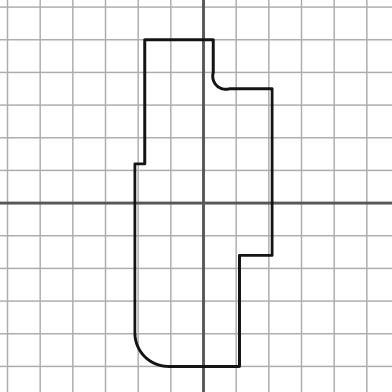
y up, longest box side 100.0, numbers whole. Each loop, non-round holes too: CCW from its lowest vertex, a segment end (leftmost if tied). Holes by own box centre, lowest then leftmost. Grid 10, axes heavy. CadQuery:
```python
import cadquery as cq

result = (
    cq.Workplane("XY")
    .moveTo(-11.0, -50.0)
    .lineTo(11.0, -50.0)
    .lineTo(11.0, -16.0)
    .lineTo(21.0, -16.0)
    .lineTo(21.0, 35.0)
    .lineTo(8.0, 35.0)
    .threePointArc((4.0, 36.0), (3.0, 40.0))
    .lineTo(3.0, 50.0)
    .lineTo(-18.0, 50.0)
    .lineTo(-18.0, 12.0)
    .lineTo(-21.0, 12.0)
    .lineTo(-21.0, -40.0)
    .threePointArc((-18.0, -47.0), (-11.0, -50.0))
    .close()
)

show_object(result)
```